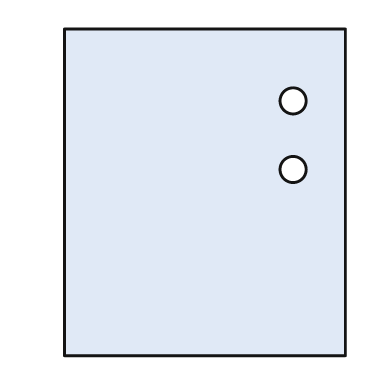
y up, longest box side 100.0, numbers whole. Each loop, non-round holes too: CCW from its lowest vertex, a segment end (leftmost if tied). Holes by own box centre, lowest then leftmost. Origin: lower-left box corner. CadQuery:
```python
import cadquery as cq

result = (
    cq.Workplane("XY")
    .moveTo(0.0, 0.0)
    .lineTo(86.0, 0.0)
    .lineTo(86.0, 100.0)
    .lineTo(0.0, 100.0)
    .close()
    .moveTo(70.0, 57.0)
    .circle(4.0)
    .moveTo(70.0, 78.0)
    .circle(4.0)
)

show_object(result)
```